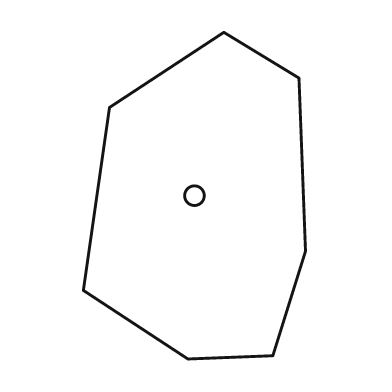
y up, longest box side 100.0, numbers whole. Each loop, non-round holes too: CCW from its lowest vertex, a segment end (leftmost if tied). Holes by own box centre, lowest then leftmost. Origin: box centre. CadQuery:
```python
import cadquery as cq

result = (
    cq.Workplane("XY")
    .moveTo(-2.0, -50.0)
    .lineTo(24.0, -49.0)
    .lineTo(34.0, -17.0)
    .lineTo(32.0, 36.0)
    .lineTo(9.0, 50.0)
    .lineTo(-26.0, 27.0)
    .lineTo(-34.0, -29.0)
    .close()
    .moveTo(0.0, 0.0)
    .circle(3.0)
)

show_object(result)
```